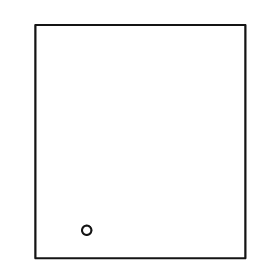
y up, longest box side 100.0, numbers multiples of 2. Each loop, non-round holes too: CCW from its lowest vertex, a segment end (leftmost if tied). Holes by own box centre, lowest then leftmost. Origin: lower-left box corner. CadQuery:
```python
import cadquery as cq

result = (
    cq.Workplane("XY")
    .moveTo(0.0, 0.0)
    .lineTo(90.0, 0.0)
    .lineTo(90.0, 100.0)
    .lineTo(0.0, 100.0)
    .close()
    .moveTo(22.0, 12.0)
    .circle(2.0)
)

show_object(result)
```